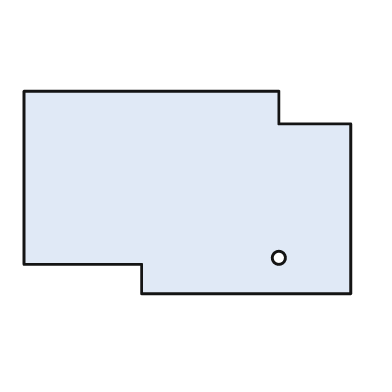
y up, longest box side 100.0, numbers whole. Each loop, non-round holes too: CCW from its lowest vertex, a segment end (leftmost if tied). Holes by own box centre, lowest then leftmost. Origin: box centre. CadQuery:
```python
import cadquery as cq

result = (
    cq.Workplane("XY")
    .moveTo(-14.0, -31.0)
    .lineTo(50.0, -31.0)
    .lineTo(50.0, 21.0)
    .lineTo(28.0, 21.0)
    .lineTo(28.0, 31.0)
    .lineTo(-50.0, 31.0)
    .lineTo(-50.0, -22.0)
    .lineTo(-14.0, -22.0)
    .close()
    .moveTo(28.0, -20.0)
    .circle(2.0)
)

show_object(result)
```